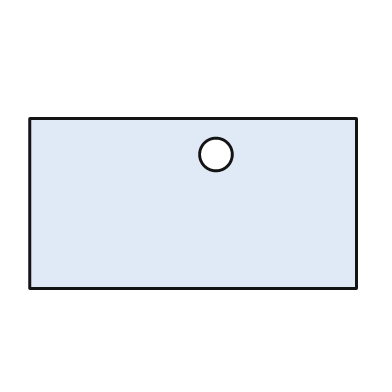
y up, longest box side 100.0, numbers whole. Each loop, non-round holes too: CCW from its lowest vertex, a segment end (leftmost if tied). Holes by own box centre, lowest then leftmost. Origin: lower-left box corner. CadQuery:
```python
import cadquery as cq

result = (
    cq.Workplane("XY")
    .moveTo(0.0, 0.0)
    .lineTo(100.0, 0.0)
    .lineTo(100.0, 52.0)
    .lineTo(0.0, 52.0)
    .close()
    .moveTo(57.0, 41.0)
    .circle(5.0)
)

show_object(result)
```